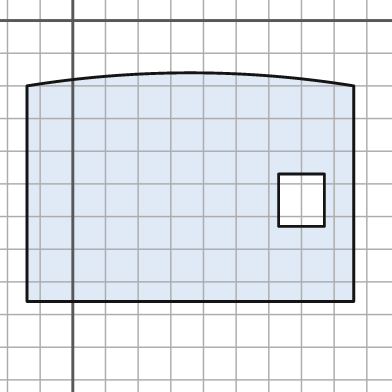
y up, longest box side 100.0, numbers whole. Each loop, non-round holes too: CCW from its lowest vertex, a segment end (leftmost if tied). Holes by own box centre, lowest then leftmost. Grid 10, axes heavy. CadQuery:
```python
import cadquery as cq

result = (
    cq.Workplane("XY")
    .moveTo(-14.0, -86.0)
    .lineTo(86.0, -86.0)
    .lineTo(86.0, -20.0)
    .threePointArc((36.0, -16.0), (-14.0, -20.0))
    .close()
    .moveTo(63.0, -63.0)
    .lineTo(77.0, -63.0)
    .lineTo(77.0, -47.0)
    .lineTo(63.0, -47.0)
    .close()
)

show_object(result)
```